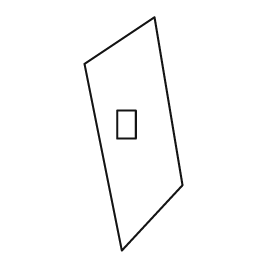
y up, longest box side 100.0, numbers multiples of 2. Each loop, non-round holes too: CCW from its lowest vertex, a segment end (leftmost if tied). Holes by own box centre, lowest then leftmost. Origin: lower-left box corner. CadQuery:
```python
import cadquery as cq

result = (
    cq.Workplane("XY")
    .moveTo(16.0, 0.0)
    .lineTo(42.0, 28.0)
    .lineTo(30.0, 100.0)
    .lineTo(0.0, 80.0)
    .close()
    .moveTo(14.0, 48.0)
    .lineTo(22.0, 48.0)
    .lineTo(22.0, 60.0)
    .lineTo(14.0, 60.0)
    .close()
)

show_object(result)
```